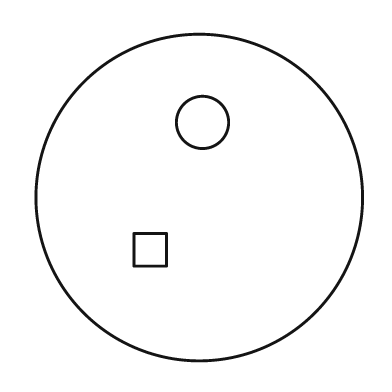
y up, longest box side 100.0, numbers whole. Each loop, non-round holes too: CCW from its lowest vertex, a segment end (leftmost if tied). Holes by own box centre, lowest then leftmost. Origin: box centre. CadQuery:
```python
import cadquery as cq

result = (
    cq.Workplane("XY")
    .moveTo(0.0, 0.0)
    .circle(50.0)
    .moveTo(-20.0, -21.0)
    .lineTo(-10.0, -21.0)
    .lineTo(-10.0, -11.0)
    .lineTo(-20.0, -11.0)
    .close()
    .moveTo(1.0, 23.0)
    .circle(8.0)
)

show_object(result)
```